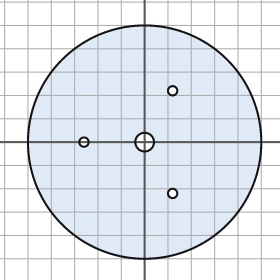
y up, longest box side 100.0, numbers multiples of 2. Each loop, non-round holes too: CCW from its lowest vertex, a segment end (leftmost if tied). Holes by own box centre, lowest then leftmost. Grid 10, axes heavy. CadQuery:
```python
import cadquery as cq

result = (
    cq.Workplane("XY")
    .moveTo(0.0, 0.0)
    .circle(50.0)
    .moveTo(12.0, -22.0)
    .circle(2.0)
    .moveTo(-26.0, 0.0)
    .circle(2.0)
    .moveTo(0.0, 0.0)
    .circle(4.0)
    .moveTo(12.0, 22.0)
    .circle(2.0)
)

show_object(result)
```